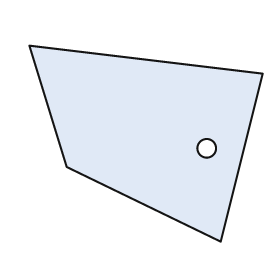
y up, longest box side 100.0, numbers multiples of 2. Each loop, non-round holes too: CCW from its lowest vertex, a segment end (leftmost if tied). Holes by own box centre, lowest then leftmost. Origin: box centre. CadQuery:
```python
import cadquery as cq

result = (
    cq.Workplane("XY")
    .moveTo(32.0, -42.0)
    .lineTo(50.0, 30.0)
    .lineTo(-50.0, 42.0)
    .lineTo(-34.0, -10.0)
    .close()
    .moveTo(26.0, -2.0)
    .circle(4.0)
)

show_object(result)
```